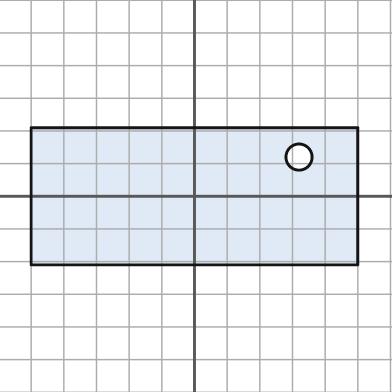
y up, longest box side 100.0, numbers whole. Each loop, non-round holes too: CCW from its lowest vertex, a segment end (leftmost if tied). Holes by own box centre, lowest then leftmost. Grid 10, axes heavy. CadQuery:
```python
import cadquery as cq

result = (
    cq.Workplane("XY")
    .moveTo(-50.0, -21.0)
    .lineTo(50.0, -21.0)
    .lineTo(50.0, 21.0)
    .lineTo(-50.0, 21.0)
    .close()
    .moveTo(32.0, 12.0)
    .circle(4.0)
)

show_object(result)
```